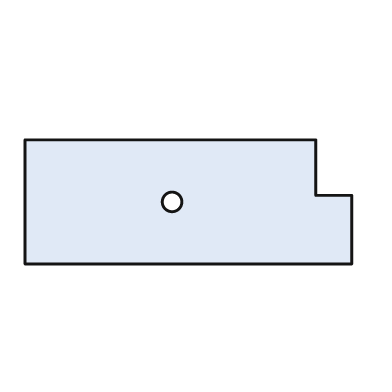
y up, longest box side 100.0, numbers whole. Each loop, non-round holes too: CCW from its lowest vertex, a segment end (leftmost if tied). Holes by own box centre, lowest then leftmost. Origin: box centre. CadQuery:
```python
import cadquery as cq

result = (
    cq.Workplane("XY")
    .moveTo(-50.0, -19.0)
    .lineTo(50.0, -19.0)
    .lineTo(50.0, 2.0)
    .lineTo(39.0, 2.0)
    .lineTo(39.0, 19.0)
    .lineTo(-50.0, 19.0)
    .close()
    .moveTo(-5.0, 0.0)
    .circle(3.0)
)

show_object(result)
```